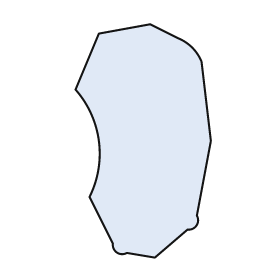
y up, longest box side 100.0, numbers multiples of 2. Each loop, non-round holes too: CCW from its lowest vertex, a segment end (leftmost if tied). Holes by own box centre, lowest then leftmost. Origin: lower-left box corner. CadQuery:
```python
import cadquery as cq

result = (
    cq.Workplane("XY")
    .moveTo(34.0, 0.0)
    .lineTo(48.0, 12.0)
    .threePointArc((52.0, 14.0), (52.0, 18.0))
    .lineTo(58.0, 50.0)
    .lineTo(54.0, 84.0)
    .threePointArc((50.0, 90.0), (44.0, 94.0))
    .lineTo(32.0, 100.0)
    .lineTo(10.0, 96.0)
    .lineTo(0.0, 72.0)
    .threePointArc((10.0, 50.0), (6.0, 26.0))
    .lineTo(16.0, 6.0)
    .threePointArc((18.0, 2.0), (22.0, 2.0))
    .close()
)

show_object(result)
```